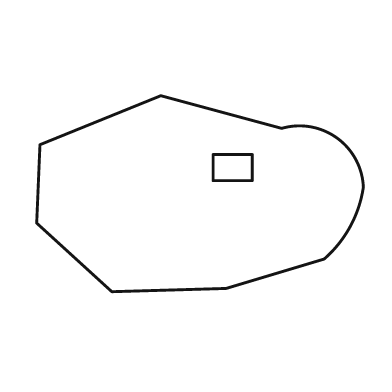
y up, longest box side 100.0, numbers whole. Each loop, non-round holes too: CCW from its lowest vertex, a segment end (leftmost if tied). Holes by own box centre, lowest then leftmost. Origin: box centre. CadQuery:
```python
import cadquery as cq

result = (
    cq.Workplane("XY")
    .moveTo(-27.0, -30.0)
    .lineTo(8.0, -29.0)
    .lineTo(38.0, -20.0)
    .threePointArc((46.0, -10.0), (50.0, 2.0))
    .threePointArc((42.0, 17.0), (25.0, 20.0))
    .lineTo(-12.0, 30.0)
    .lineTo(-49.0, 15.0)
    .lineTo(-50.0, -9.0)
    .close()
    .moveTo(4.0, 4.0)
    .lineTo(16.0, 4.0)
    .lineTo(16.0, 12.0)
    .lineTo(4.0, 12.0)
    .close()
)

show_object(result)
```